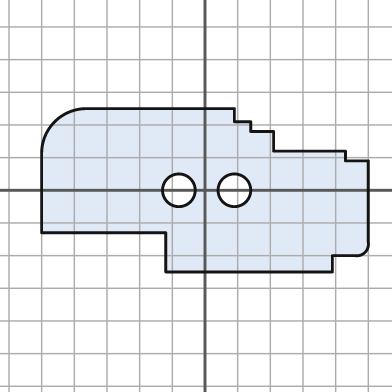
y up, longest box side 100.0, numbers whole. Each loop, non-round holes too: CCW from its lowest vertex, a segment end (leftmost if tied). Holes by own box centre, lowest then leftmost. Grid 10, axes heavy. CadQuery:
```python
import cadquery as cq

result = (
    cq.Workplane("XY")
    .moveTo(-12.0, -25.0)
    .lineTo(39.0, -25.0)
    .lineTo(39.0, -20.0)
    .lineTo(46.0, -20.0)
    .threePointArc((49.0, -19.0), (50.0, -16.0))
    .lineTo(50.0, 9.0)
    .lineTo(43.0, 9.0)
    .lineTo(43.0, 12.0)
    .lineTo(21.0, 12.0)
    .lineTo(21.0, 18.0)
    .lineTo(14.0, 18.0)
    .lineTo(14.0, 21.0)
    .lineTo(9.0, 21.0)
    .lineTo(9.0, 25.0)
    .lineTo(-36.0, 25.0)
    .threePointArc((-46.0, 21.0), (-50.0, 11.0))
    .lineTo(-50.0, -13.0)
    .lineTo(-12.0, -13.0)
    .close()
    .moveTo(-8.0, 0.0)
    .circle(5.0)
    .moveTo(9.0, 0.0)
    .circle(5.0)
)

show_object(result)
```